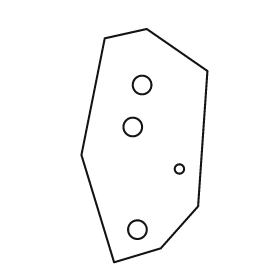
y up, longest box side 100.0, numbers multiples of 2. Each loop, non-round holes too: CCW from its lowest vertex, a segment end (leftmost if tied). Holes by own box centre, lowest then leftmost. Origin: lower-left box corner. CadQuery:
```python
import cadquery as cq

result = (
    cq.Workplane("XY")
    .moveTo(14.0, 0.0)
    .lineTo(34.0, 6.0)
    .lineTo(50.0, 24.0)
    .lineTo(54.0, 82.0)
    .lineTo(28.0, 100.0)
    .lineTo(10.0, 96.0)
    .lineTo(0.0, 46.0)
    .close()
    .moveTo(24.0, 14.0)
    .circle(4.0)
    .moveTo(42.0, 40.0)
    .circle(2.0)
    .moveTo(22.0, 58.0)
    .circle(4.0)
    .moveTo(26.0, 76.0)
    .circle(4.0)
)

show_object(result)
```